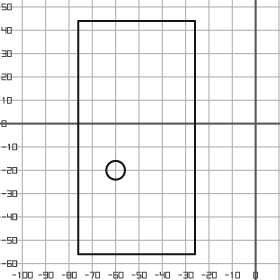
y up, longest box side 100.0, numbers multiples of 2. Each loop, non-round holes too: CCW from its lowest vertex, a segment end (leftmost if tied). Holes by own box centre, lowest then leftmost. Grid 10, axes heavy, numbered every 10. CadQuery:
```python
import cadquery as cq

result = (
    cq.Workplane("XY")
    .moveTo(-76.0, -56.0)
    .lineTo(-26.0, -56.0)
    .lineTo(-26.0, 44.0)
    .lineTo(-76.0, 44.0)
    .close()
    .moveTo(-60.0, -20.0)
    .circle(4.0)
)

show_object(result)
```